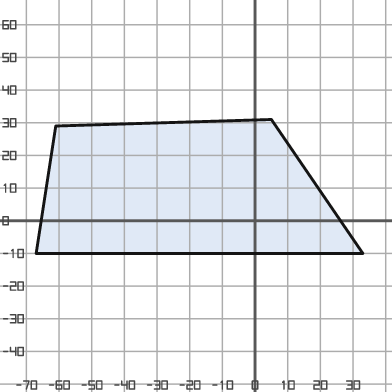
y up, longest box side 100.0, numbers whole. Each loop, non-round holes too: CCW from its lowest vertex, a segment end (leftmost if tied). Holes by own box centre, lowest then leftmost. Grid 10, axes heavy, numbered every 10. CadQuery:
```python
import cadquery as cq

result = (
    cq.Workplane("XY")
    .moveTo(-67.0, -10.0)
    .lineTo(33.0, -10.0)
    .lineTo(5.0, 31.0)
    .lineTo(-61.0, 29.0)
    .close()
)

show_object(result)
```